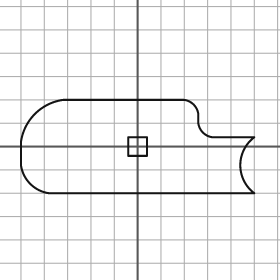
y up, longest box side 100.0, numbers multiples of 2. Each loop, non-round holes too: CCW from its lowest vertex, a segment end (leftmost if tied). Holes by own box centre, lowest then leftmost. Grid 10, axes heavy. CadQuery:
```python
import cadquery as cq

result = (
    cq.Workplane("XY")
    .moveTo(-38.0, -20.0)
    .lineTo(50.0, -20.0)
    .threePointArc((44.0, -8.0), (50.0, 4.0))
    .lineTo(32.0, 4.0)
    .threePointArc((28.0, 6.0), (26.0, 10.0))
    .lineTo(26.0, 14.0)
    .threePointArc((24.0, 18.0), (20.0, 20.0))
    .lineTo(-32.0, 20.0)
    .threePointArc((-44.0, 14.0), (-50.0, 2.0))
    .lineTo(-50.0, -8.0)
    .threePointArc((-46.0, -16.0), (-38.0, -20.0))
    .close()
    .moveTo(-4.0, -4.0)
    .lineTo(4.0, -4.0)
    .lineTo(4.0, 4.0)
    .lineTo(-4.0, 4.0)
    .close()
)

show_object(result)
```